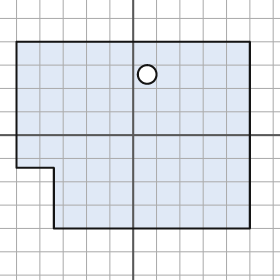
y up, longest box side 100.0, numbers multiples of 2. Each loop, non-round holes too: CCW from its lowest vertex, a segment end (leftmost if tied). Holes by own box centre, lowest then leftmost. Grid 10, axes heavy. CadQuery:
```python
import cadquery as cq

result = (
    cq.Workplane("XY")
    .moveTo(-34.0, -40.0)
    .lineTo(50.0, -40.0)
    .lineTo(50.0, 40.0)
    .lineTo(-50.0, 40.0)
    .lineTo(-50.0, -14.0)
    .lineTo(-34.0, -14.0)
    .close()
    .moveTo(6.0, 26.0)
    .circle(4.0)
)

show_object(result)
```